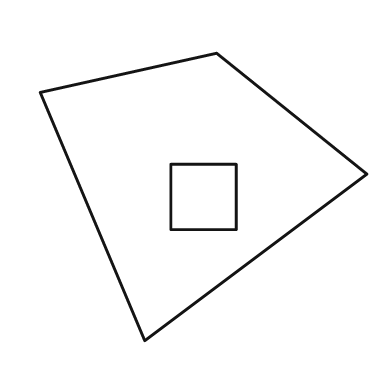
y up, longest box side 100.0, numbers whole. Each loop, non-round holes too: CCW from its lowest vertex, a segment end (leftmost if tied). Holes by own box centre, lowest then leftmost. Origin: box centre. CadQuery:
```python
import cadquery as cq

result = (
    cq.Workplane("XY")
    .moveTo(-18.0, -44.0)
    .lineTo(50.0, 7.0)
    .lineTo(4.0, 44.0)
    .lineTo(-50.0, 32.0)
    .close()
    .moveTo(-10.0, -10.0)
    .lineTo(10.0, -10.0)
    .lineTo(10.0, 10.0)
    .lineTo(-10.0, 10.0)
    .close()
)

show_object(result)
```